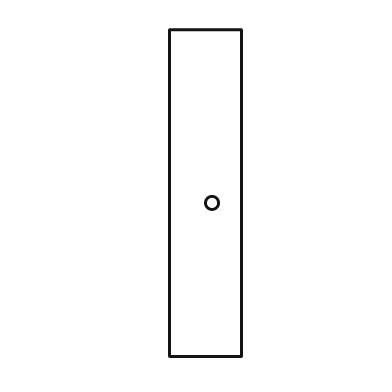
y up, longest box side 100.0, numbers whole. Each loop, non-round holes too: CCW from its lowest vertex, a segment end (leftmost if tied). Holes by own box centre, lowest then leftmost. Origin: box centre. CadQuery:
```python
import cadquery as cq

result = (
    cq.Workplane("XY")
    .moveTo(-11.0, -50.0)
    .lineTo(11.0, -50.0)
    .lineTo(11.0, 50.0)
    .lineTo(-11.0, 50.0)
    .close()
    .moveTo(2.0, -3.0)
    .circle(2.0)
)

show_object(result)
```